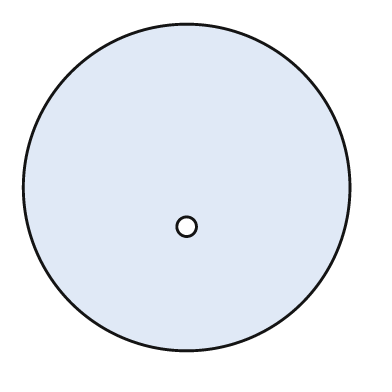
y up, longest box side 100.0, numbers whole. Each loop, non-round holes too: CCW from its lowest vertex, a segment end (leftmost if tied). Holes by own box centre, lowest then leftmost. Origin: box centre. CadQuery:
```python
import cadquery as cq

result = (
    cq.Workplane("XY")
    .moveTo(0.0, 0.0)
    .circle(50.0)
    .moveTo(0.0, -12.0)
    .circle(3.0)
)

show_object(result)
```